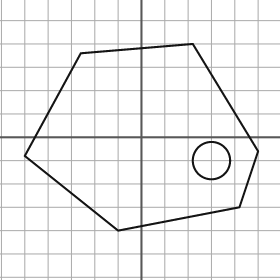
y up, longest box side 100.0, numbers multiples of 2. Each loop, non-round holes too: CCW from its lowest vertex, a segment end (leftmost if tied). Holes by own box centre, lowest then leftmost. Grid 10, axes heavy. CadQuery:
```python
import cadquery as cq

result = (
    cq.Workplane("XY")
    .moveTo(-10.0, -40.0)
    .lineTo(42.0, -30.0)
    .lineTo(50.0, -6.0)
    .lineTo(22.0, 40.0)
    .lineTo(-26.0, 36.0)
    .lineTo(-50.0, -8.0)
    .close()
    .moveTo(30.0, -10.0)
    .circle(8.0)
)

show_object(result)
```